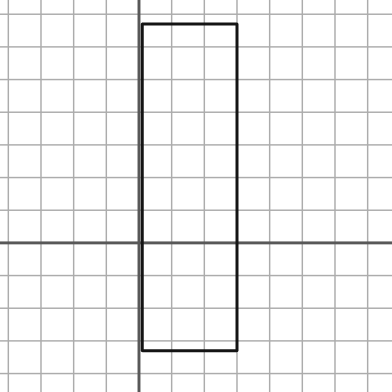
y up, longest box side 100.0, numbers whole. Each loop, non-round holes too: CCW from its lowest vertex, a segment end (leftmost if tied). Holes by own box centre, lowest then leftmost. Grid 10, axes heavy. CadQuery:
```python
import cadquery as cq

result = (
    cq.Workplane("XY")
    .moveTo(1.0, -33.0)
    .lineTo(30.0, -33.0)
    .lineTo(30.0, 67.0)
    .lineTo(1.0, 67.0)
    .close()
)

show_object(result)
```